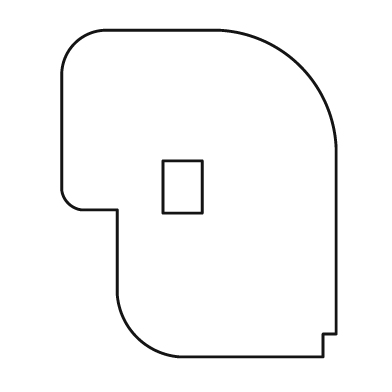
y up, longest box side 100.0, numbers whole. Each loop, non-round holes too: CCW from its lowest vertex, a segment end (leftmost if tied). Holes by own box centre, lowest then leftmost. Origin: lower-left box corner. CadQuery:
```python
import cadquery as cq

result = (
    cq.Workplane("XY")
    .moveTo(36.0, 0.0)
    .lineTo(80.0, 0.0)
    .lineTo(80.0, 7.0)
    .lineTo(84.0, 7.0)
    .lineTo(84.0, 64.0)
    .threePointArc((73.0, 89.0), (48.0, 100.0))
    .lineTo(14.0, 100.0)
    .threePointArc((4.0, 96.0), (0.0, 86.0))
    .lineTo(0.0, 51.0)
    .threePointArc((2.0, 47.0), (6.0, 45.0))
    .lineTo(17.0, 45.0)
    .lineTo(17.0, 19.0)
    .threePointArc((23.0, 6.0), (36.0, 0.0))
    .close()
    .moveTo(31.0, 44.0)
    .lineTo(43.0, 44.0)
    .lineTo(43.0, 60.0)
    .lineTo(31.0, 60.0)
    .close()
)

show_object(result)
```